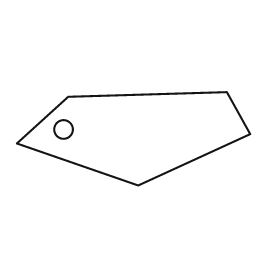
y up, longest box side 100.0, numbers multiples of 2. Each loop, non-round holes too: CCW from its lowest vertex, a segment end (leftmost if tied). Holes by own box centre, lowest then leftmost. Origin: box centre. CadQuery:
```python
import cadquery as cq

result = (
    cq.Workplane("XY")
    .moveTo(2.0, -20.0)
    .lineTo(50.0, 2.0)
    .lineTo(40.0, 20.0)
    .lineTo(-28.0, 18.0)
    .lineTo(-50.0, -2.0)
    .close()
    .moveTo(-30.0, 4.0)
    .circle(4.0)
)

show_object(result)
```